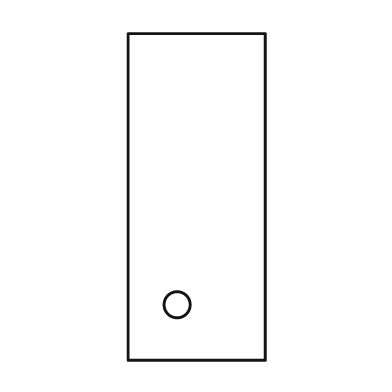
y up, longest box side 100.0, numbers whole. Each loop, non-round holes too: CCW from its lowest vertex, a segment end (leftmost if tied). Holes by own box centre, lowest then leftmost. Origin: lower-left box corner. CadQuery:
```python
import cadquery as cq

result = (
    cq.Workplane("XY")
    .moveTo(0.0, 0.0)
    .lineTo(42.0, 0.0)
    .lineTo(42.0, 100.0)
    .lineTo(0.0, 100.0)
    .close()
    .moveTo(15.0, 17.0)
    .circle(4.0)
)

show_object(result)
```